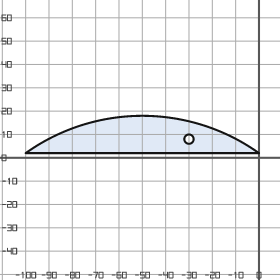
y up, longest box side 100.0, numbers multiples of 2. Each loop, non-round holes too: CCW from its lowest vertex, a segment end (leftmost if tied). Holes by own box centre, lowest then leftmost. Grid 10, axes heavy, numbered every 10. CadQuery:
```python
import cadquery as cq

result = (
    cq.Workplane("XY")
    .moveTo(-100.0, 2.0)
    .lineTo(0.0, 2.0)
    .threePointArc((-50.0, 18.0), (-100.0, 2.0))
    .close()
    .moveTo(-30.0, 8.0)
    .circle(2.0)
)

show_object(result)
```